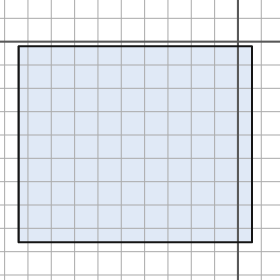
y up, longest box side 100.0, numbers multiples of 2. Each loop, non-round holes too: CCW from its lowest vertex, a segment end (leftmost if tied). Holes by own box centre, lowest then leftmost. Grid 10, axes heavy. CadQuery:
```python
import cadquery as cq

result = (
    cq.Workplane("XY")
    .moveTo(-94.0, -86.0)
    .lineTo(6.0, -86.0)
    .lineTo(6.0, -2.0)
    .lineTo(-94.0, -2.0)
    .close()
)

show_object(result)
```